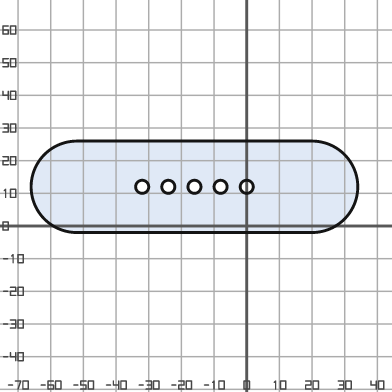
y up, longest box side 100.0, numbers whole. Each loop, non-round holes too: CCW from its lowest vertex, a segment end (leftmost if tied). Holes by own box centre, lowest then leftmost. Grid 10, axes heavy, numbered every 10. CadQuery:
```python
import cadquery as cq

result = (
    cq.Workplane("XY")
    .moveTo(-52.0, -2.0)
    .lineTo(20.0, -2.0)
    .threePointArc((34.0, 12.0), (20.0, 26.0))
    .lineTo(-52.0, 26.0)
    .threePointArc((-66.0, 12.0), (-52.0, -2.0))
    .close()
    .moveTo(-32.0, 12.0)
    .circle(2.0)
    .moveTo(-24.0, 12.0)
    .circle(2.0)
    .moveTo(-16.0, 12.0)
    .circle(2.0)
    .moveTo(-8.0, 12.0)
    .circle(2.0)
    .moveTo(0.0, 12.0)
    .circle(2.0)
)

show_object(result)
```